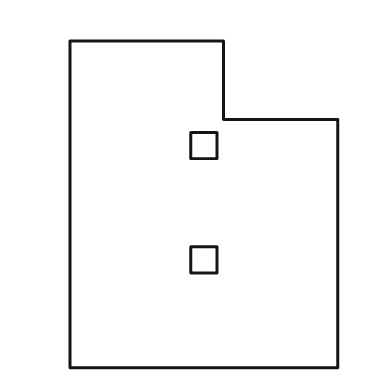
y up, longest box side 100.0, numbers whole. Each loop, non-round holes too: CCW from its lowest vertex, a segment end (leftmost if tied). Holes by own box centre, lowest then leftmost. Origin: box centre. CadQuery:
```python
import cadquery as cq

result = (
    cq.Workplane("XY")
    .moveTo(-41.0, -50.0)
    .lineTo(41.0, -50.0)
    .lineTo(41.0, 26.0)
    .lineTo(6.0, 26.0)
    .lineTo(6.0, 50.0)
    .lineTo(-41.0, 50.0)
    .close()
    .moveTo(-4.0, -21.0)
    .lineTo(4.0, -21.0)
    .lineTo(4.0, -13.0)
    .lineTo(-4.0, -13.0)
    .close()
    .moveTo(-4.0, 14.0)
    .lineTo(4.0, 14.0)
    .lineTo(4.0, 22.0)
    .lineTo(-4.0, 22.0)
    .close()
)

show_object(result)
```